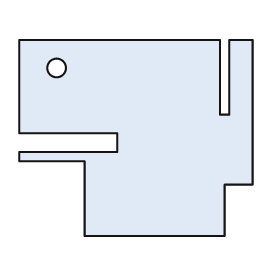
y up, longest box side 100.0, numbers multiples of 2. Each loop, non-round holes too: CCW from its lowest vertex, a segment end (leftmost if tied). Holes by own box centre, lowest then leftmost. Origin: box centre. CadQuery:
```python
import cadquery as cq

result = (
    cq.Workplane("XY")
    .moveTo(-22.0, -42.0)
    .lineTo(38.0, -42.0)
    .lineTo(38.0, -20.0)
    .lineTo(50.0, -20.0)
    .lineTo(50.0, 42.0)
    .lineTo(40.0, 42.0)
    .lineTo(40.0, 10.0)
    .lineTo(36.0, 10.0)
    .lineTo(36.0, 42.0)
    .lineTo(-50.0, 42.0)
    .lineTo(-50.0, 2.0)
    .lineTo(-8.0, 2.0)
    .lineTo(-8.0, -6.0)
    .lineTo(-50.0, -6.0)
    .lineTo(-50.0, -10.0)
    .lineTo(-22.0, -10.0)
    .close()
    .moveTo(-34.0, 30.0)
    .circle(4.0)
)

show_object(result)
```